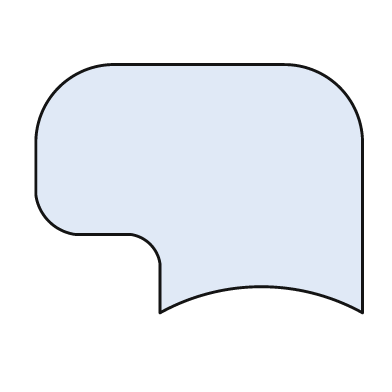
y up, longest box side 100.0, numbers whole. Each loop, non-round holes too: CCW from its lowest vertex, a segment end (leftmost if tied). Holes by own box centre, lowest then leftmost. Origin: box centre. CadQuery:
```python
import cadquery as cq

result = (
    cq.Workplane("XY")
    .moveTo(-12.0, -38.0)
    .threePointArc((19.0, -30.0), (50.0, -38.0))
    .lineTo(50.0, 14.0)
    .threePointArc((43.0, 31.0), (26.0, 38.0))
    .lineTo(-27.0, 38.0)
    .threePointArc((-43.0, 31.0), (-50.0, 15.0))
    .lineTo(-50.0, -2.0)
    .threePointArc((-46.0, -10.0), (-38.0, -14.0))
    .lineTo(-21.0, -14.0)
    .threePointArc((-15.0, -17.0), (-12.0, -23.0))
    .close()
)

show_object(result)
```